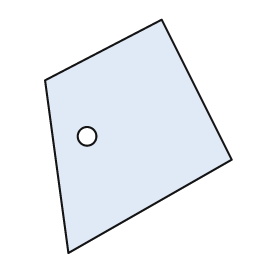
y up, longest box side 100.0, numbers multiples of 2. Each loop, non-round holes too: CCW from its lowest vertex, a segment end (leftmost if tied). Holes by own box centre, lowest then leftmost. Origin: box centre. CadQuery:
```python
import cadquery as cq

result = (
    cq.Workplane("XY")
    .moveTo(-30.0, -50.0)
    .lineTo(40.0, -10.0)
    .lineTo(10.0, 50.0)
    .lineTo(-40.0, 24.0)
    .close()
    .moveTo(-22.0, 0.0)
    .circle(4.0)
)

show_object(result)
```